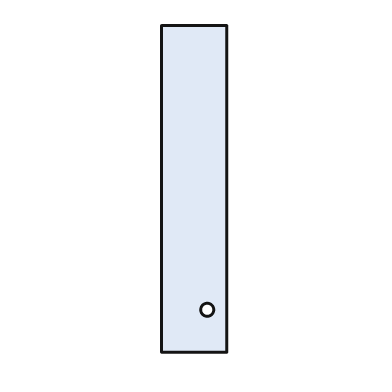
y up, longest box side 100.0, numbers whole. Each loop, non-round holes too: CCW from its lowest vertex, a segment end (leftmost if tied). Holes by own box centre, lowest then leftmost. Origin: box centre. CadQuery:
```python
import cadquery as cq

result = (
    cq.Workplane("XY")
    .moveTo(-10.0, -50.0)
    .lineTo(10.0, -50.0)
    .lineTo(10.0, 50.0)
    .lineTo(-10.0, 50.0)
    .close()
    .moveTo(4.0, -37.0)
    .circle(2.0)
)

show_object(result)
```